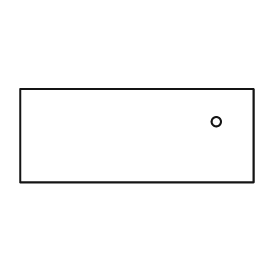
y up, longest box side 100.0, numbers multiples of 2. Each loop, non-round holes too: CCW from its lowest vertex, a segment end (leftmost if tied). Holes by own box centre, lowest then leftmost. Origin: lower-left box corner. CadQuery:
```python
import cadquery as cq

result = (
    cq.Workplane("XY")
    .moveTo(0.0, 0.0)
    .lineTo(100.0, 0.0)
    .lineTo(100.0, 40.0)
    .lineTo(0.0, 40.0)
    .close()
    .moveTo(84.0, 26.0)
    .circle(2.0)
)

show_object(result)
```